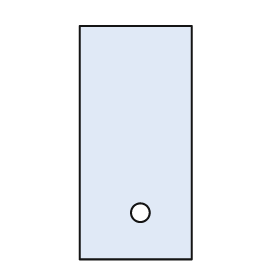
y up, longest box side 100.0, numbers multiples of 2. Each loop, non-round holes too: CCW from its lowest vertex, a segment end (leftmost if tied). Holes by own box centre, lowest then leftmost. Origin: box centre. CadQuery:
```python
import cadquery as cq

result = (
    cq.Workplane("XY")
    .moveTo(-24.0, -50.0)
    .lineTo(24.0, -50.0)
    .lineTo(24.0, 50.0)
    .lineTo(-24.0, 50.0)
    .close()
    .moveTo(2.0, -30.0)
    .circle(4.0)
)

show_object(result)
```